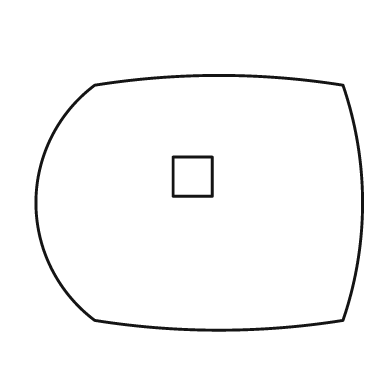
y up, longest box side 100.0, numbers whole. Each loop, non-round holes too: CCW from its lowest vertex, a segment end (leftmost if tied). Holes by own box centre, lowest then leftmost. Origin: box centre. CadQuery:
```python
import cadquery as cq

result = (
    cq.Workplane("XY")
    .moveTo(-32.0, -36.0)
    .threePointArc((6.0, -39.0), (44.0, -36.0))
    .threePointArc((50.0, 0.0), (44.0, 36.0))
    .threePointArc((6.0, 39.0), (-32.0, 36.0))
    .threePointArc((-50.0, 0.0), (-32.0, -36.0))
    .close()
    .moveTo(-8.0, 2.0)
    .lineTo(4.0, 2.0)
    .lineTo(4.0, 14.0)
    .lineTo(-8.0, 14.0)
    .close()
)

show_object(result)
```